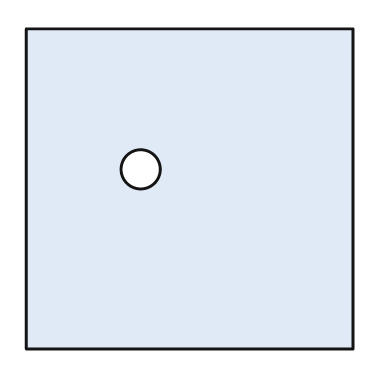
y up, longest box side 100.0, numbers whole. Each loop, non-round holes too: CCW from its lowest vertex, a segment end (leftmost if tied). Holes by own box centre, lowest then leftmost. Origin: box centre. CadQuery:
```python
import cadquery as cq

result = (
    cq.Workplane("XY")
    .moveTo(-50.0, -49.0)
    .lineTo(50.0, -49.0)
    .lineTo(50.0, 49.0)
    .lineTo(-50.0, 49.0)
    .close()
    .moveTo(-15.0, 6.0)
    .circle(6.0)
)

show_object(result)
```